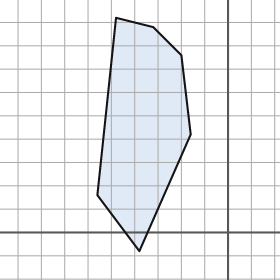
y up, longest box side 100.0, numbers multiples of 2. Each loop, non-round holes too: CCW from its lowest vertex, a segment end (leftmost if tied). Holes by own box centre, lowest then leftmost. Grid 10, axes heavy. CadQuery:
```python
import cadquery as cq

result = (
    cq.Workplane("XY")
    .moveTo(-38.0, -8.0)
    .lineTo(-16.0, 42.0)
    .lineTo(-20.0, 76.0)
    .lineTo(-32.0, 88.0)
    .lineTo(-48.0, 92.0)
    .lineTo(-56.0, 16.0)
    .close()
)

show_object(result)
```